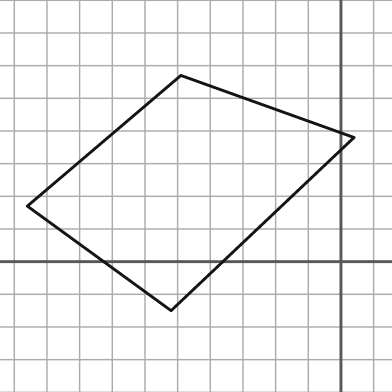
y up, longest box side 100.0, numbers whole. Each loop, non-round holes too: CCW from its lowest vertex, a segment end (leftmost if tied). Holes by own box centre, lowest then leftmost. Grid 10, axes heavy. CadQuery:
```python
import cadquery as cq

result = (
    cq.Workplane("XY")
    .moveTo(-52.0, -15.0)
    .lineTo(4.0, 38.0)
    .lineTo(-49.0, 57.0)
    .lineTo(-96.0, 17.0)
    .close()
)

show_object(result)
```